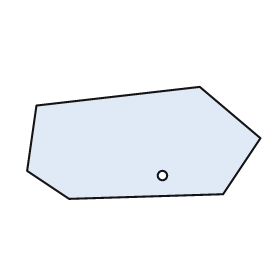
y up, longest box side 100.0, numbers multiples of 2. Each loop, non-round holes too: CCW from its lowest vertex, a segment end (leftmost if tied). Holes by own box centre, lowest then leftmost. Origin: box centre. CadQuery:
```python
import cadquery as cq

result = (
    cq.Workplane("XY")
    .moveTo(-32.0, -24.0)
    .lineTo(34.0, -22.0)
    .lineTo(50.0, 2.0)
    .lineTo(24.0, 24.0)
    .lineTo(-46.0, 16.0)
    .lineTo(-50.0, -12.0)
    .close()
    .moveTo(8.0, -14.0)
    .circle(2.0)
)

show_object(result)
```